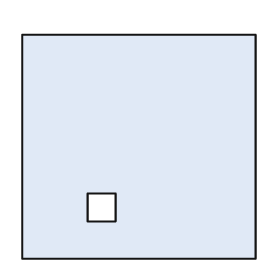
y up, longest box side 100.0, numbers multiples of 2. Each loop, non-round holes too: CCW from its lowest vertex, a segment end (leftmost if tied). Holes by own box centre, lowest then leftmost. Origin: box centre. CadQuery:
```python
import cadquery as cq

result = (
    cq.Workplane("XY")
    .moveTo(-50.0, -48.0)
    .lineTo(50.0, -48.0)
    .lineTo(50.0, 48.0)
    .lineTo(-50.0, 48.0)
    .close()
    .moveTo(-22.0, -32.0)
    .lineTo(-10.0, -32.0)
    .lineTo(-10.0, -20.0)
    .lineTo(-22.0, -20.0)
    .close()
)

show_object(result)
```